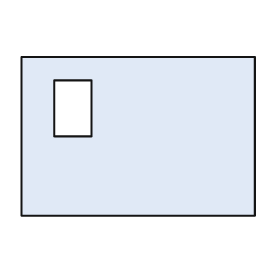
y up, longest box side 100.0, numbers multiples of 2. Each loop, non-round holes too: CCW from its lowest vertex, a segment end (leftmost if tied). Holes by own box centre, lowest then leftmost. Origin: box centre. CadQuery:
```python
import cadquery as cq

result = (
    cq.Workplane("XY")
    .moveTo(-50.0, -34.0)
    .lineTo(50.0, -34.0)
    .lineTo(50.0, 34.0)
    .lineTo(-50.0, 34.0)
    .close()
    .moveTo(-36.0, 0.0)
    .lineTo(-20.0, 0.0)
    .lineTo(-20.0, 24.0)
    .lineTo(-36.0, 24.0)
    .close()
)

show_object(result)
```